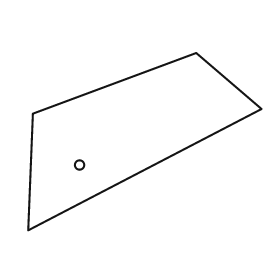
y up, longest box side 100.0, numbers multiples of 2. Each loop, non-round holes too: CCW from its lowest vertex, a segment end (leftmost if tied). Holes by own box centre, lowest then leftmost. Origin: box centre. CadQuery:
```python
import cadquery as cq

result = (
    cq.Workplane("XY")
    .moveTo(-50.0, -38.0)
    .lineTo(50.0, 14.0)
    .lineTo(22.0, 38.0)
    .lineTo(-48.0, 12.0)
    .close()
    .moveTo(-28.0, -10.0)
    .circle(2.0)
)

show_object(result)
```